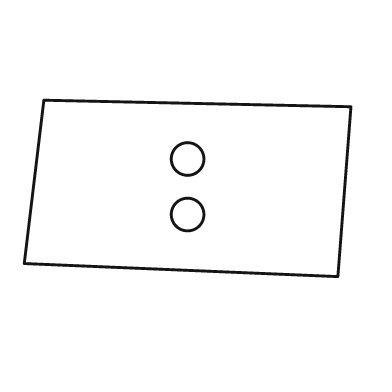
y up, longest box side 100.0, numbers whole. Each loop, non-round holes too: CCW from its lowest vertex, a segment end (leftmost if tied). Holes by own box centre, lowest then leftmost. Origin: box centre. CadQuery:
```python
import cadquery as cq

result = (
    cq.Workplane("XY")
    .moveTo(46.0, -27.0)
    .lineTo(50.0, 25.0)
    .lineTo(-44.0, 27.0)
    .lineTo(-50.0, -23.0)
    .close()
    .moveTo(0.0, -8.0)
    .circle(5.0)
    .moveTo(0.0, 9.0)
    .circle(5.0)
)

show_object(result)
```